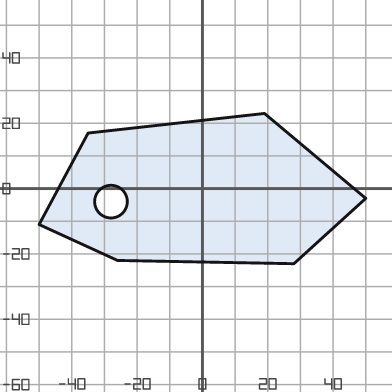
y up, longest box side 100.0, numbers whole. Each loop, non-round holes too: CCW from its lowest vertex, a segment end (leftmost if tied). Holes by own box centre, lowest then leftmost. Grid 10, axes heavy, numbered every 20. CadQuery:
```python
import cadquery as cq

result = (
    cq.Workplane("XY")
    .moveTo(28.0, -23.0)
    .lineTo(50.0, -3.0)
    .lineTo(19.0, 23.0)
    .lineTo(-35.0, 17.0)
    .lineTo(-50.0, -11.0)
    .lineTo(-26.0, -22.0)
    .close()
    .moveTo(-28.0, -4.0)
    .circle(5.0)
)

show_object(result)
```